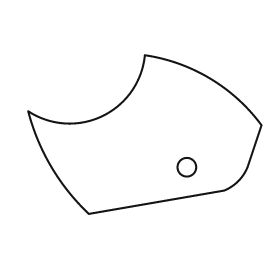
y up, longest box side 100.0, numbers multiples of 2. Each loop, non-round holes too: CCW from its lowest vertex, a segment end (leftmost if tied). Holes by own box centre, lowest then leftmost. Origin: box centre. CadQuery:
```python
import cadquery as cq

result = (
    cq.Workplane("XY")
    .moveTo(-24.0, -34.0)
    .lineTo(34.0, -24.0)
    .threePointArc((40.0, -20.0), (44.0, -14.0))
    .lineTo(50.0, 4.0)
    .threePointArc((28.0, 24.0), (0.0, 34.0))
    .threePointArc((-18.0, 8.0), (-50.0, 10.0))
    .threePointArc((-40.0, -14.0), (-24.0, -34.0))
    .close()
    .moveTo(18.0, -14.0)
    .circle(4.0)
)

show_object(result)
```